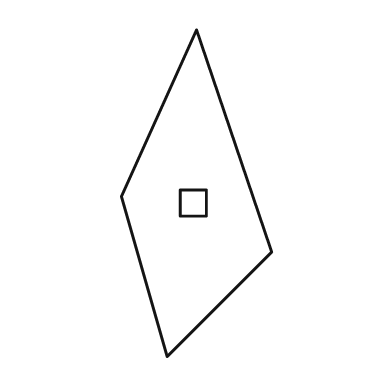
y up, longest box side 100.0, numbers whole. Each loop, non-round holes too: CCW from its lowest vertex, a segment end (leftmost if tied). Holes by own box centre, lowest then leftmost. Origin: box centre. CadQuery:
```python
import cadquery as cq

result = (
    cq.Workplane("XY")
    .moveTo(-9.0, -50.0)
    .lineTo(23.0, -18.0)
    .lineTo(0.0, 50.0)
    .lineTo(-23.0, -1.0)
    .close()
    .moveTo(-5.0, -7.0)
    .lineTo(3.0, -7.0)
    .lineTo(3.0, 1.0)
    .lineTo(-5.0, 1.0)
    .close()
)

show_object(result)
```